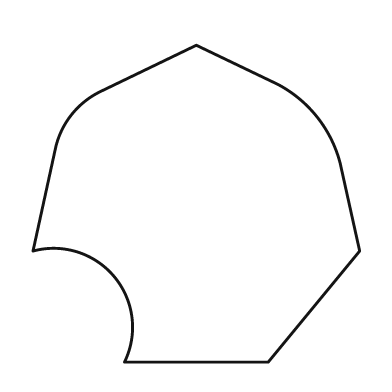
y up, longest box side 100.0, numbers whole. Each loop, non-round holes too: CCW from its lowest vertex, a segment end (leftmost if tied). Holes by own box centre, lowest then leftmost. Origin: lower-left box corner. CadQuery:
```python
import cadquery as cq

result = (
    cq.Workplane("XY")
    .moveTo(28.0, 0.0)
    .lineTo(72.0, 0.0)
    .lineTo(100.0, 34.0)
    .lineTo(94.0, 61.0)
    .threePointArc((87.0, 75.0), (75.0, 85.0))
    .lineTo(50.0, 97.0)
    .lineTo(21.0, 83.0)
    .threePointArc((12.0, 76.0), (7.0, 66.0))
    .lineTo(0.0, 34.0)
    .threePointArc((25.0, 26.0), (28.0, 0.0))
    .close()
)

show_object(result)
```